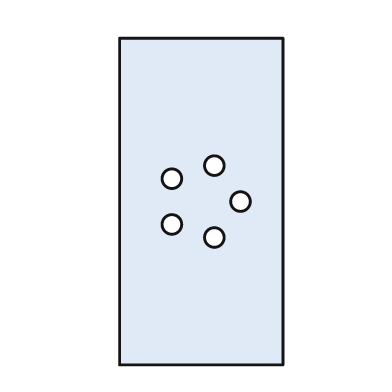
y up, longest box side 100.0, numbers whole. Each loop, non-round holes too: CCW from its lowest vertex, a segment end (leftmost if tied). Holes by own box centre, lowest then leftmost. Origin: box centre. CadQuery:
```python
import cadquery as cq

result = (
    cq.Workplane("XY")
    .moveTo(-25.0, -50.0)
    .lineTo(25.0, -50.0)
    .lineTo(25.0, 50.0)
    .lineTo(-25.0, 50.0)
    .close()
    .moveTo(4.0, -11.0)
    .circle(3.0)
    .moveTo(-9.0, -7.0)
    .circle(3.0)
    .moveTo(12.0, 0.0)
    .circle(3.0)
    .moveTo(-9.0, 7.0)
    .circle(3.0)
    .moveTo(4.0, 11.0)
    .circle(3.0)
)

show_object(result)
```